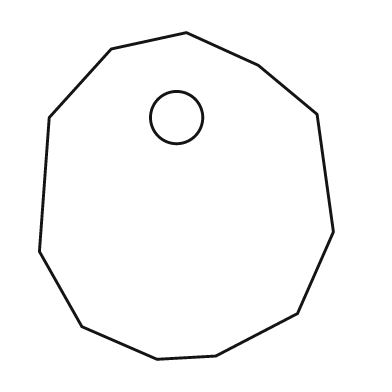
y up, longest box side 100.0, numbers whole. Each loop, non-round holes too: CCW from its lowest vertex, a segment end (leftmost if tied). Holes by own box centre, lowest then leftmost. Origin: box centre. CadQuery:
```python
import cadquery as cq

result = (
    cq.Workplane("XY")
    .moveTo(-9.0, -50.0)
    .lineTo(9.0, -49.0)
    .lineTo(34.0, -36.0)
    .lineTo(45.0, -11.0)
    .lineTo(40.0, 25.0)
    .lineTo(22.0, 40.0)
    .lineTo(0.0, 50.0)
    .lineTo(-23.0, 45.0)
    .lineTo(-42.0, 24.0)
    .lineTo(-45.0, -17.0)
    .lineTo(-32.0, -40.0)
    .close()
    .moveTo(-3.0, 24.0)
    .circle(8.0)
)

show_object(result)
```